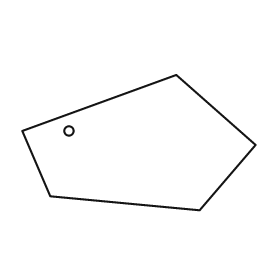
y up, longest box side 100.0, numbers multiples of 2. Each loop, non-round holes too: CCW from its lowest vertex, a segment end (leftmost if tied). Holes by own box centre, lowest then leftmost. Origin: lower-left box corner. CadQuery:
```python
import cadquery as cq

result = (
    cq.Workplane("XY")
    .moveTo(76.0, 0.0)
    .lineTo(100.0, 28.0)
    .lineTo(66.0, 58.0)
    .lineTo(0.0, 34.0)
    .lineTo(12.0, 6.0)
    .close()
    .moveTo(20.0, 34.0)
    .circle(2.0)
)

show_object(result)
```